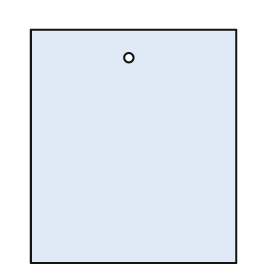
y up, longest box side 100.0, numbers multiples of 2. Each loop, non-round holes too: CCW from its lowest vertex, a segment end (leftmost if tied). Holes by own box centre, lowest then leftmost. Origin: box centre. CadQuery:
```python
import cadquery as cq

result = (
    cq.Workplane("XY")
    .moveTo(-44.0, -50.0)
    .lineTo(44.0, -50.0)
    .lineTo(44.0, 50.0)
    .lineTo(-44.0, 50.0)
    .close()
    .moveTo(-2.0, 38.0)
    .circle(2.0)
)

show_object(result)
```